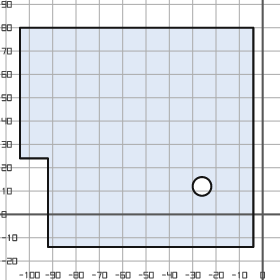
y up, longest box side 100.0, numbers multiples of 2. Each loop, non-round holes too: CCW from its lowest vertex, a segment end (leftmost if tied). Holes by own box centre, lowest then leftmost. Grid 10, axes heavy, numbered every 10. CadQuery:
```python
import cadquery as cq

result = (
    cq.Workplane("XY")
    .moveTo(-92.0, -14.0)
    .lineTo(-4.0, -14.0)
    .lineTo(-4.0, 80.0)
    .lineTo(-104.0, 80.0)
    .lineTo(-104.0, 24.0)
    .lineTo(-92.0, 24.0)
    .close()
    .moveTo(-26.0, 12.0)
    .circle(4.0)
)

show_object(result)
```